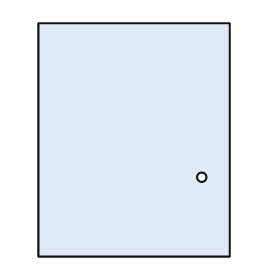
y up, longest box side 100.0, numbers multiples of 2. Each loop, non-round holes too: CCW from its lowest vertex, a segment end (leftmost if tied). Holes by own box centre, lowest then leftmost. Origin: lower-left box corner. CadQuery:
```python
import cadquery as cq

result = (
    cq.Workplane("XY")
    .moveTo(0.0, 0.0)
    .lineTo(82.0, 0.0)
    .lineTo(82.0, 100.0)
    .lineTo(0.0, 100.0)
    .close()
    .moveTo(70.0, 34.0)
    .circle(2.0)
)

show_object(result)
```